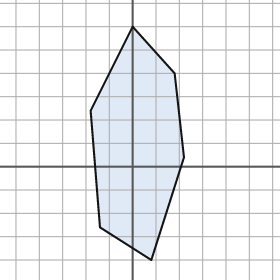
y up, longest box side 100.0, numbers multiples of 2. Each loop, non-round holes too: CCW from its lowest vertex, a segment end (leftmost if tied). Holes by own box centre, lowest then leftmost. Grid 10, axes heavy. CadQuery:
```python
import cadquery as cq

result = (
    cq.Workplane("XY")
    .moveTo(8.0, -40.0)
    .lineTo(22.0, 4.0)
    .lineTo(18.0, 40.0)
    .lineTo(0.0, 60.0)
    .lineTo(-18.0, 24.0)
    .lineTo(-14.0, -26.0)
    .close()
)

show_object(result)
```